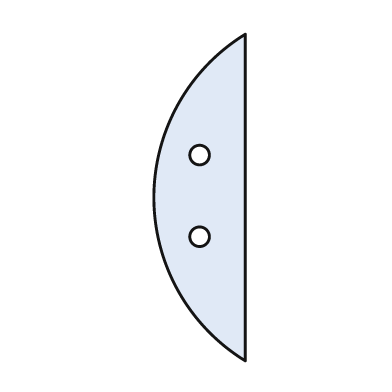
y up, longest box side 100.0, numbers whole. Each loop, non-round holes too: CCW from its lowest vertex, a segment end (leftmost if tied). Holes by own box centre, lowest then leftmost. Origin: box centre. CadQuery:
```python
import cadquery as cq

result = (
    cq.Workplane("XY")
    .moveTo(14.0, -50.0)
    .lineTo(14.0, 50.0)
    .threePointArc((-14.0, 0.0), (14.0, -50.0))
    .close()
    .moveTo(0.0, -12.0)
    .circle(3.0)
    .moveTo(0.0, 13.0)
    .circle(3.0)
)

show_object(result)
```